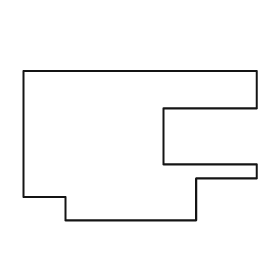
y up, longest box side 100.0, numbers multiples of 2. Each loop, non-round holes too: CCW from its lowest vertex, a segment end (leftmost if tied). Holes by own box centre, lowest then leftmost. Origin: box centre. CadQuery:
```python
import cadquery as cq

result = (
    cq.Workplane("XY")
    .moveTo(-32.0, -32.0)
    .lineTo(24.0, -32.0)
    .lineTo(24.0, -14.0)
    .lineTo(50.0, -14.0)
    .lineTo(50.0, -8.0)
    .lineTo(10.0, -8.0)
    .lineTo(10.0, 16.0)
    .lineTo(50.0, 16.0)
    .lineTo(50.0, 32.0)
    .lineTo(-50.0, 32.0)
    .lineTo(-50.0, -22.0)
    .lineTo(-32.0, -22.0)
    .close()
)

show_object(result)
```